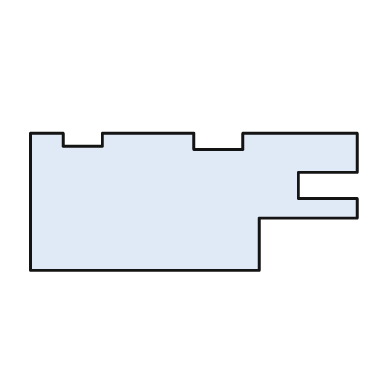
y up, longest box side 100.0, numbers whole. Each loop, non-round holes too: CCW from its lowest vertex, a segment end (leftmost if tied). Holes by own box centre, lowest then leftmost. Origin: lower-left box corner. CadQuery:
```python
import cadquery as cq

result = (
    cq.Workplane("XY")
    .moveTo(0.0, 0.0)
    .lineTo(70.0, 0.0)
    .lineTo(70.0, 16.0)
    .lineTo(100.0, 16.0)
    .lineTo(100.0, 22.0)
    .lineTo(82.0, 22.0)
    .lineTo(82.0, 30.0)
    .lineTo(100.0, 30.0)
    .lineTo(100.0, 42.0)
    .lineTo(65.0, 42.0)
    .lineTo(65.0, 37.0)
    .lineTo(50.0, 37.0)
    .lineTo(50.0, 42.0)
    .lineTo(22.0, 42.0)
    .lineTo(22.0, 38.0)
    .lineTo(10.0, 38.0)
    .lineTo(10.0, 42.0)
    .lineTo(0.0, 42.0)
    .close()
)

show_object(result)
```